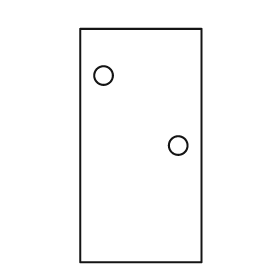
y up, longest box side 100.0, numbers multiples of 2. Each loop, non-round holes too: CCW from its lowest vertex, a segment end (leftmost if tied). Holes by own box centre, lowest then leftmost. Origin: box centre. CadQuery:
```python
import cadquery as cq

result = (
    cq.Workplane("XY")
    .moveTo(-26.0, -50.0)
    .lineTo(26.0, -50.0)
    .lineTo(26.0, 50.0)
    .lineTo(-26.0, 50.0)
    .close()
    .moveTo(16.0, 0.0)
    .circle(4.0)
    .moveTo(-16.0, 30.0)
    .circle(4.0)
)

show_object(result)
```